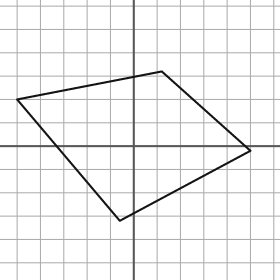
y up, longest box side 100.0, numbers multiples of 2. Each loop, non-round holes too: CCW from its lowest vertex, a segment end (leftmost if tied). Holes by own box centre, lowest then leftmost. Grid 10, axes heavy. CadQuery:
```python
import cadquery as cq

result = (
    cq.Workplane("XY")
    .moveTo(-6.0, -32.0)
    .lineTo(50.0, -2.0)
    .lineTo(12.0, 32.0)
    .lineTo(-50.0, 20.0)
    .close()
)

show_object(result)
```